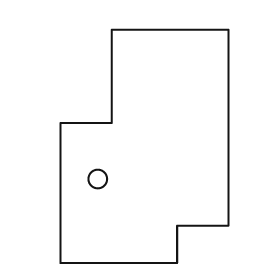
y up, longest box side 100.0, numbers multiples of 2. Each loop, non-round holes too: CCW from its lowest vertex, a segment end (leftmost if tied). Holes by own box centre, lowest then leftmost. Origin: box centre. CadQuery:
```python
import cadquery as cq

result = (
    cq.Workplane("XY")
    .moveTo(-36.0, -50.0)
    .lineTo(14.0, -50.0)
    .lineTo(14.0, -34.0)
    .lineTo(36.0, -34.0)
    .lineTo(36.0, 50.0)
    .lineTo(-14.0, 50.0)
    .lineTo(-14.0, 10.0)
    .lineTo(-36.0, 10.0)
    .close()
    .moveTo(-20.0, -14.0)
    .circle(4.0)
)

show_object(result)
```